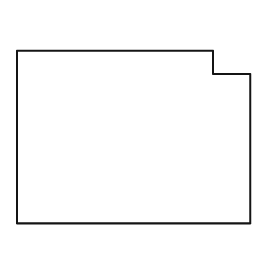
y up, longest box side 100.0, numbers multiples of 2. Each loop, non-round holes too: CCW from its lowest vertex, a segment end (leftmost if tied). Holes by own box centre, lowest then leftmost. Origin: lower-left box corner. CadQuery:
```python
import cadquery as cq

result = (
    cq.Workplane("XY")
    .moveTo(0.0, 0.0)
    .lineTo(100.0, 0.0)
    .lineTo(100.0, 64.0)
    .lineTo(84.0, 64.0)
    .lineTo(84.0, 74.0)
    .lineTo(0.0, 74.0)
    .close()
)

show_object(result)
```